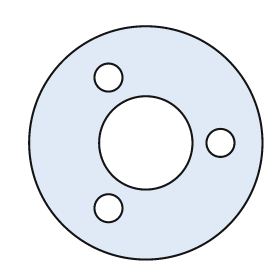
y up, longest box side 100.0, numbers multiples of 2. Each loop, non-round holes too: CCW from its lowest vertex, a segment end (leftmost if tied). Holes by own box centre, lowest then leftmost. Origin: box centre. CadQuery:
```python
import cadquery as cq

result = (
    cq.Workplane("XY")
    .moveTo(0.0, 0.0)
    .circle(50.0)
    .moveTo(-16.0, -28.0)
    .circle(6.0)
    .moveTo(0.0, 0.0)
    .circle(20.0)
    .moveTo(32.0, 0.0)
    .circle(6.0)
    .moveTo(-16.0, 28.0)
    .circle(6.0)
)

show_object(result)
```